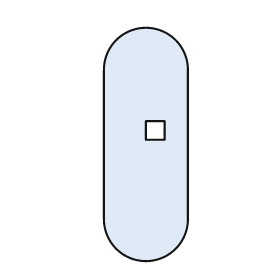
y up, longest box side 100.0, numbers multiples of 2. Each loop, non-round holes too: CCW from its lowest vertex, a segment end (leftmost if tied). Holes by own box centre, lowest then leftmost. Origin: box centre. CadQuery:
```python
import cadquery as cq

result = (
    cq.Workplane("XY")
    .moveTo(-18.0, -32.0)
    .threePointArc((0.0, -50.0), (18.0, -32.0))
    .lineTo(18.0, 32.0)
    .threePointArc((0.0, 50.0), (-18.0, 32.0))
    .close()
    .moveTo(0.0, 2.0)
    .lineTo(8.0, 2.0)
    .lineTo(8.0, 10.0)
    .lineTo(0.0, 10.0)
    .close()
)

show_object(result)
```